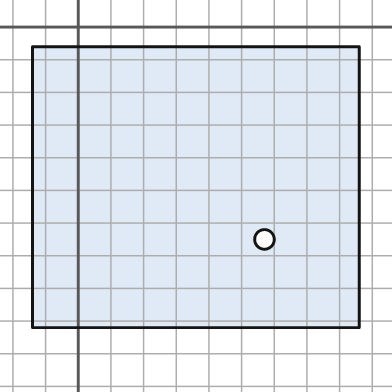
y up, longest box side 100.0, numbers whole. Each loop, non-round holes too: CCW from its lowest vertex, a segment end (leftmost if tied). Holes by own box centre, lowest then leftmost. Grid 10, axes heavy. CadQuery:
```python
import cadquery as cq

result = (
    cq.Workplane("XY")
    .moveTo(-14.0, -92.0)
    .lineTo(86.0, -92.0)
    .lineTo(86.0, -6.0)
    .lineTo(-14.0, -6.0)
    .close()
    .moveTo(57.0, -65.0)
    .circle(3.0)
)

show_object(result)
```